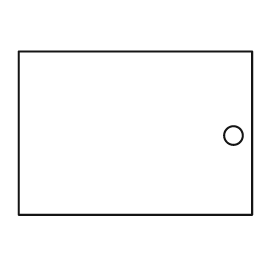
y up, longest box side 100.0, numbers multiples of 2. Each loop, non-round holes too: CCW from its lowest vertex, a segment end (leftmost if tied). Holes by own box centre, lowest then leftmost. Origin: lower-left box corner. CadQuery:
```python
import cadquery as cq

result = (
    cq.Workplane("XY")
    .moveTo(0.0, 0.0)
    .lineTo(100.0, 0.0)
    .lineTo(100.0, 70.0)
    .lineTo(0.0, 70.0)
    .close()
    .moveTo(92.0, 34.0)
    .circle(4.0)
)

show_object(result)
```